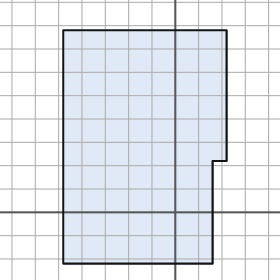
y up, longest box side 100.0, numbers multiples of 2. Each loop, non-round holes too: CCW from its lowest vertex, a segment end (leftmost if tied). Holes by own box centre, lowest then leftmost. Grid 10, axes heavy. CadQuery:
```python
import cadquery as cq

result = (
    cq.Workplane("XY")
    .moveTo(-48.0, -22.0)
    .lineTo(16.0, -22.0)
    .lineTo(16.0, 22.0)
    .lineTo(22.0, 22.0)
    .lineTo(22.0, 78.0)
    .lineTo(-48.0, 78.0)
    .close()
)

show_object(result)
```